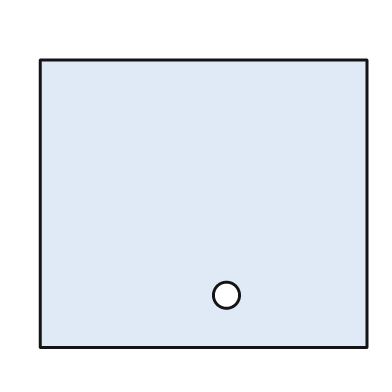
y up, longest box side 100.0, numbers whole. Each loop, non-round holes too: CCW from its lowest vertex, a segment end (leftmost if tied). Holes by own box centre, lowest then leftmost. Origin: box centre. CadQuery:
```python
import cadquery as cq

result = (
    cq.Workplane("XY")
    .moveTo(-50.0, -44.0)
    .lineTo(50.0, -44.0)
    .lineTo(50.0, 44.0)
    .lineTo(-50.0, 44.0)
    .close()
    .moveTo(7.0, -28.0)
    .circle(4.0)
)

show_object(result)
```